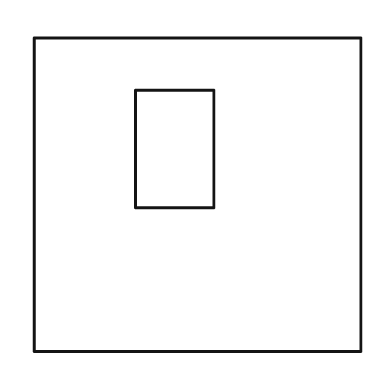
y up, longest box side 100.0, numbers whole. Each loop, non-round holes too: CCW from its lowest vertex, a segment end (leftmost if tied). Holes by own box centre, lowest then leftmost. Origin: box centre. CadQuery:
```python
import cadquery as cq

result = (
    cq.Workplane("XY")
    .moveTo(-50.0, -48.0)
    .lineTo(50.0, -48.0)
    .lineTo(50.0, 48.0)
    .lineTo(-50.0, 48.0)
    .close()
    .moveTo(-19.0, -4.0)
    .lineTo(5.0, -4.0)
    .lineTo(5.0, 32.0)
    .lineTo(-19.0, 32.0)
    .close()
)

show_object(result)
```